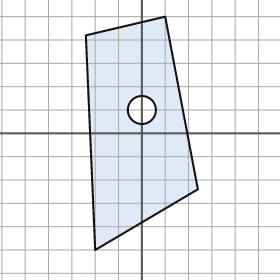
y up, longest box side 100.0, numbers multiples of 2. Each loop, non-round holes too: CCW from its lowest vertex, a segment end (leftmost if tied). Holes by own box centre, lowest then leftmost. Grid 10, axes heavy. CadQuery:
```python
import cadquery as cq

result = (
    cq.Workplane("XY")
    .moveTo(-20.0, -50.0)
    .lineTo(24.0, -24.0)
    .lineTo(10.0, 50.0)
    .lineTo(-24.0, 42.0)
    .close()
    .moveTo(0.0, 10.0)
    .circle(6.0)
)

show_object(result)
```